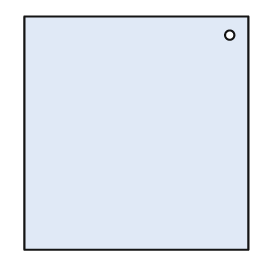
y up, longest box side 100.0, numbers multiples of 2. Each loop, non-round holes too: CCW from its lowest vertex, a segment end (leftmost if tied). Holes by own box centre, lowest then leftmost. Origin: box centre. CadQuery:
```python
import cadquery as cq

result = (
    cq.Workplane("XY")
    .moveTo(-48.0, -50.0)
    .lineTo(48.0, -50.0)
    .lineTo(48.0, 50.0)
    .lineTo(-48.0, 50.0)
    .close()
    .moveTo(40.0, 42.0)
    .circle(2.0)
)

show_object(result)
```